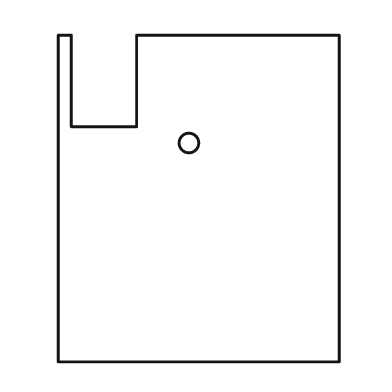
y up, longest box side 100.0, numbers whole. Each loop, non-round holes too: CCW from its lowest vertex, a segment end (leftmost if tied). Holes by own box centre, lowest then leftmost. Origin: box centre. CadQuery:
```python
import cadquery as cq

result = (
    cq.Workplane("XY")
    .moveTo(-43.0, -50.0)
    .lineTo(43.0, -50.0)
    .lineTo(43.0, 50.0)
    .lineTo(-19.0, 50.0)
    .lineTo(-19.0, 22.0)
    .lineTo(-39.0, 22.0)
    .lineTo(-39.0, 50.0)
    .lineTo(-43.0, 50.0)
    .close()
    .moveTo(-3.0, 17.0)
    .circle(3.0)
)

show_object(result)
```